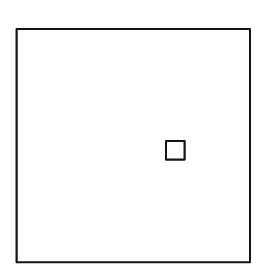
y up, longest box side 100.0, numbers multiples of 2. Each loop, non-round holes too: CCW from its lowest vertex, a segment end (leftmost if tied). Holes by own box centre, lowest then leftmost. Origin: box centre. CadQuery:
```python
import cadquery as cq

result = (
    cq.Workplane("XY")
    .moveTo(-50.0, -50.0)
    .lineTo(50.0, -50.0)
    .lineTo(50.0, 50.0)
    .lineTo(-50.0, 50.0)
    .close()
    .moveTo(14.0, -6.0)
    .lineTo(22.0, -6.0)
    .lineTo(22.0, 2.0)
    .lineTo(14.0, 2.0)
    .close()
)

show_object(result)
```